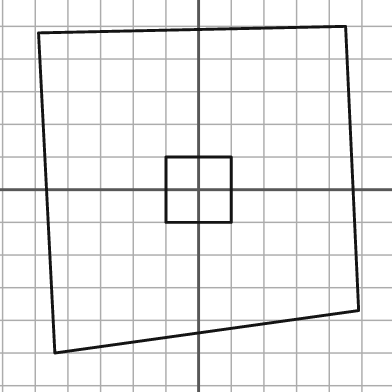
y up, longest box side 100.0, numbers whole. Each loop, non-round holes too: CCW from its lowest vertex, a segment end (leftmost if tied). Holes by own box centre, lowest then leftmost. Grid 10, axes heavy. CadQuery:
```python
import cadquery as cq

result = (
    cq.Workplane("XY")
    .moveTo(-44.0, -50.0)
    .lineTo(49.0, -37.0)
    .lineTo(45.0, 50.0)
    .lineTo(-49.0, 48.0)
    .close()
    .moveTo(-10.0, -10.0)
    .lineTo(10.0, -10.0)
    .lineTo(10.0, 10.0)
    .lineTo(-10.0, 10.0)
    .close()
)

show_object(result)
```